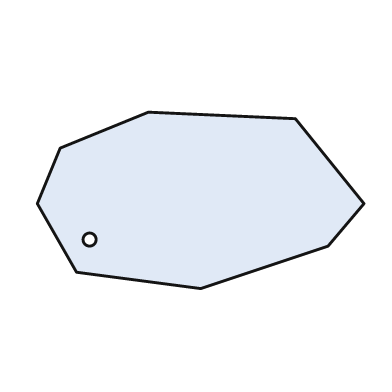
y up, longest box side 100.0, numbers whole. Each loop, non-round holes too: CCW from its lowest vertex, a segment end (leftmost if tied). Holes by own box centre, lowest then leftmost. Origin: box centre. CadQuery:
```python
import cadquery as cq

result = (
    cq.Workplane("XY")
    .moveTo(0.0, -27.0)
    .lineTo(39.0, -14.0)
    .lineTo(50.0, -1.0)
    .lineTo(29.0, 25.0)
    .lineTo(-16.0, 27.0)
    .lineTo(-43.0, 16.0)
    .lineTo(-50.0, -1.0)
    .lineTo(-38.0, -22.0)
    .close()
    .moveTo(-34.0, -12.0)
    .circle(2.0)
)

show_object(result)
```